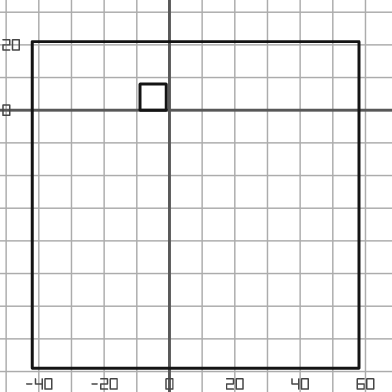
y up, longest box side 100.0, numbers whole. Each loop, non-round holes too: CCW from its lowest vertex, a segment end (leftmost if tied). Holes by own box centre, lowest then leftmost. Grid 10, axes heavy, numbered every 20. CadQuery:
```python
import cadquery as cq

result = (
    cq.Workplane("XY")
    .moveTo(-42.0, -79.0)
    .lineTo(58.0, -79.0)
    .lineTo(58.0, 21.0)
    .lineTo(-42.0, 21.0)
    .close()
    .moveTo(-9.0, 0.0)
    .lineTo(-1.0, 0.0)
    .lineTo(-1.0, 8.0)
    .lineTo(-9.0, 8.0)
    .close()
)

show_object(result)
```